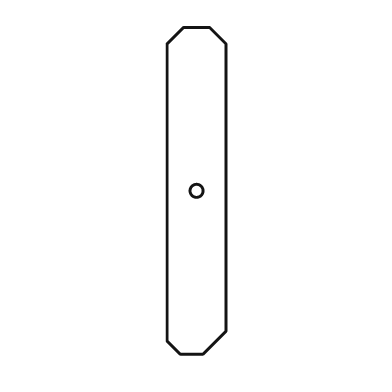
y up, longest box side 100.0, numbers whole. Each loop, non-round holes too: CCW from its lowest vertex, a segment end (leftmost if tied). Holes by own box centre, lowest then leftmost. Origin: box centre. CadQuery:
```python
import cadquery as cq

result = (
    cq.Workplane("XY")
    .moveTo(-5.0, -50.0)
    .lineTo(2.0, -50.0)
    .lineTo(9.0, -43.0)
    .lineTo(9.0, 45.0)
    .lineTo(4.0, 50.0)
    .lineTo(-4.0, 50.0)
    .lineTo(-9.0, 45.0)
    .lineTo(-9.0, -46.0)
    .close()
    .moveTo(0.0, 0.0)
    .circle(2.0)
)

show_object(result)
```